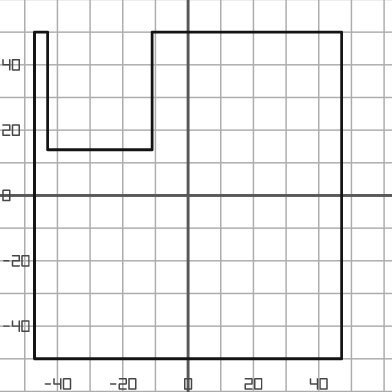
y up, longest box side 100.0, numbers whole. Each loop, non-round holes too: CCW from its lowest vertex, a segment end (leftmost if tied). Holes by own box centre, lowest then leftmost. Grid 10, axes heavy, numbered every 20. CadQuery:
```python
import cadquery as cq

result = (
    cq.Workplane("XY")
    .moveTo(-47.0, -50.0)
    .lineTo(47.0, -50.0)
    .lineTo(47.0, 50.0)
    .lineTo(-11.0, 50.0)
    .lineTo(-11.0, 14.0)
    .lineTo(-43.0, 14.0)
    .lineTo(-43.0, 50.0)
    .lineTo(-47.0, 50.0)
    .close()
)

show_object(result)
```